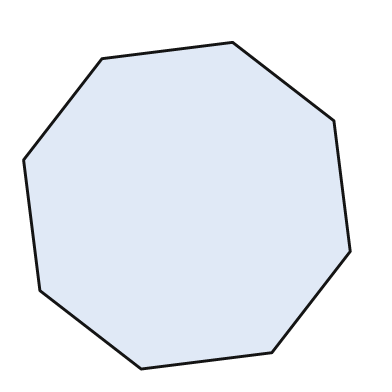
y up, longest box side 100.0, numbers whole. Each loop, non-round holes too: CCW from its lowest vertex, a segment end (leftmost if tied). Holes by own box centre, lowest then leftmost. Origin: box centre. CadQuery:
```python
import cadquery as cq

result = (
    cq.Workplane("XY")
    .moveTo(-14.0, -50.0)
    .lineTo(26.0, -45.0)
    .lineTo(50.0, -14.0)
    .lineTo(45.0, 26.0)
    .lineTo(14.0, 50.0)
    .lineTo(-26.0, 45.0)
    .lineTo(-50.0, 14.0)
    .lineTo(-45.0, -26.0)
    .close()
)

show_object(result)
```